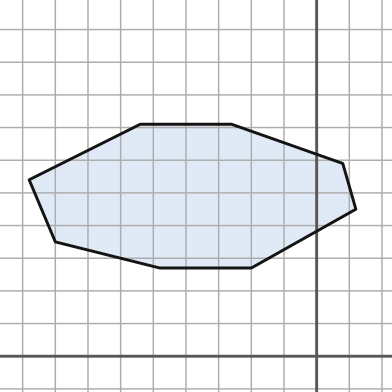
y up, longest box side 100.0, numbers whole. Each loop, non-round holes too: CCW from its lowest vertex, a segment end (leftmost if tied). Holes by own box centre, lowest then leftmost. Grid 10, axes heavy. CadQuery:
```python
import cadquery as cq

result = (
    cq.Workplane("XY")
    .moveTo(-48.0, 27.0)
    .lineTo(-20.0, 27.0)
    .lineTo(12.0, 45.0)
    .lineTo(8.0, 59.0)
    .lineTo(-26.0, 71.0)
    .lineTo(-54.0, 71.0)
    .lineTo(-88.0, 54.0)
    .lineTo(-80.0, 35.0)
    .close()
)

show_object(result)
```